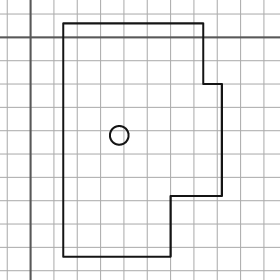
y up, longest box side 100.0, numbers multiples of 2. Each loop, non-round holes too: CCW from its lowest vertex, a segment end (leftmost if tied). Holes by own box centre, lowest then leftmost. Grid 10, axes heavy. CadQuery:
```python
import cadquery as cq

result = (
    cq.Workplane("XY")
    .moveTo(14.0, -94.0)
    .lineTo(60.0, -94.0)
    .lineTo(60.0, -68.0)
    .lineTo(82.0, -68.0)
    .lineTo(82.0, -20.0)
    .lineTo(74.0, -20.0)
    .lineTo(74.0, 6.0)
    .lineTo(14.0, 6.0)
    .close()
    .moveTo(38.0, -42.0)
    .circle(4.0)
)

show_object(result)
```